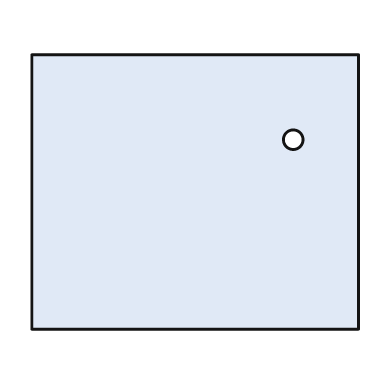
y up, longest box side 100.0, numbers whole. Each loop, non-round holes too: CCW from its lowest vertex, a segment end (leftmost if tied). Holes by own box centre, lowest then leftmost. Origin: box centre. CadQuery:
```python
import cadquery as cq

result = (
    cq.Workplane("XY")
    .moveTo(-50.0, -42.0)
    .lineTo(50.0, -42.0)
    .lineTo(50.0, 42.0)
    .lineTo(-50.0, 42.0)
    .close()
    .moveTo(30.0, 16.0)
    .circle(3.0)
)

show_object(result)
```